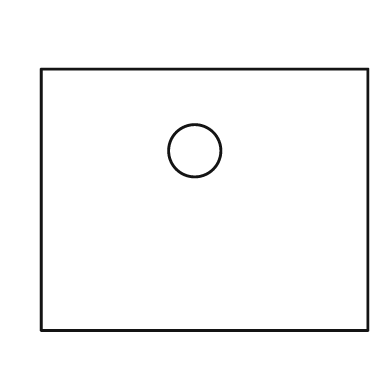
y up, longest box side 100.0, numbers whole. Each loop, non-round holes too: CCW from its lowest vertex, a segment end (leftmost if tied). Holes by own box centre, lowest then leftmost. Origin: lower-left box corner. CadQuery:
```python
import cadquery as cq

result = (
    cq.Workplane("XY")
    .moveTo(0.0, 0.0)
    .lineTo(100.0, 0.0)
    .lineTo(100.0, 80.0)
    .lineTo(0.0, 80.0)
    .close()
    .moveTo(47.0, 55.0)
    .circle(8.0)
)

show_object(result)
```